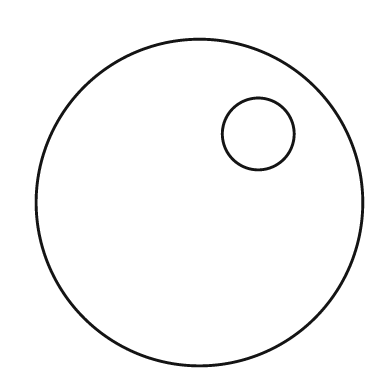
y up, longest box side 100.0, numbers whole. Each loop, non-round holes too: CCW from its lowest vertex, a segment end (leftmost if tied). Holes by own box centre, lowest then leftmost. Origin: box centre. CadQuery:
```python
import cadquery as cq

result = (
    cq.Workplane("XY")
    .moveTo(0.0, 0.0)
    .circle(50.0)
    .moveTo(18.0, 21.0)
    .circle(11.0)
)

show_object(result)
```